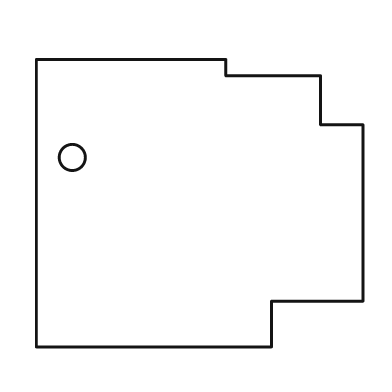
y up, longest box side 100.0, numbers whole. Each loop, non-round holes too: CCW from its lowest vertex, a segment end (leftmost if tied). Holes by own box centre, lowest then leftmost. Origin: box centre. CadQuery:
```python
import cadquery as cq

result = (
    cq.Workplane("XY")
    .moveTo(-50.0, -44.0)
    .lineTo(22.0, -44.0)
    .lineTo(22.0, -30.0)
    .lineTo(50.0, -30.0)
    .lineTo(50.0, 24.0)
    .lineTo(37.0, 24.0)
    .lineTo(37.0, 39.0)
    .lineTo(8.0, 39.0)
    .lineTo(8.0, 44.0)
    .lineTo(-50.0, 44.0)
    .close()
    .moveTo(-39.0, 14.0)
    .circle(4.0)
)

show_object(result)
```